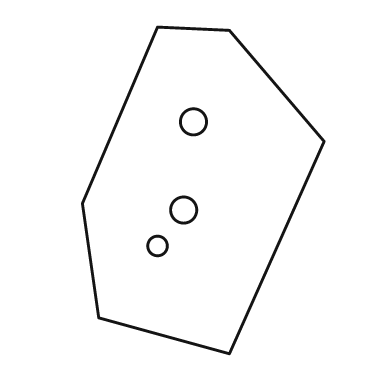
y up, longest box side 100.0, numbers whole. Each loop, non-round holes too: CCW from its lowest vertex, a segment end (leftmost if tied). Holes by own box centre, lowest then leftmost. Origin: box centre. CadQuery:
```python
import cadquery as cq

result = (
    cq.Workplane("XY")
    .moveTo(8.0, -50.0)
    .lineTo(37.0, 15.0)
    .lineTo(8.0, 49.0)
    .lineTo(-14.0, 50.0)
    .lineTo(-37.0, -4.0)
    .lineTo(-32.0, -39.0)
    .close()
    .moveTo(-14.0, -17.0)
    .circle(3.0)
    .moveTo(-6.0, -6.0)
    .circle(4.0)
    .moveTo(-3.0, 21.0)
    .circle(4.0)
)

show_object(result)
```